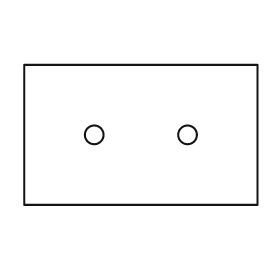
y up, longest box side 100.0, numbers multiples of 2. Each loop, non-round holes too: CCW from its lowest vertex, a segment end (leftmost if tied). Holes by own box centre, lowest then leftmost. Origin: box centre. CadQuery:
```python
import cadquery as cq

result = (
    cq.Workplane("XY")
    .moveTo(-50.0, -30.0)
    .lineTo(50.0, -30.0)
    .lineTo(50.0, 30.0)
    .lineTo(-50.0, 30.0)
    .close()
    .moveTo(-20.0, 0.0)
    .circle(4.0)
    .moveTo(20.0, 0.0)
    .circle(4.0)
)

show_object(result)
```